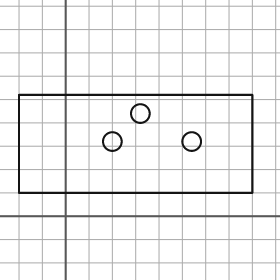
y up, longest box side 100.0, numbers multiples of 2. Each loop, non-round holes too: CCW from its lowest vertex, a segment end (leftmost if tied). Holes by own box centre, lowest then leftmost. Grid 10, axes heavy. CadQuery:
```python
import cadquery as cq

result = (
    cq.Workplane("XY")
    .moveTo(-20.0, 10.0)
    .lineTo(80.0, 10.0)
    .lineTo(80.0, 52.0)
    .lineTo(-20.0, 52.0)
    .close()
    .moveTo(20.0, 32.0)
    .circle(4.0)
    .moveTo(54.0, 32.0)
    .circle(4.0)
    .moveTo(32.0, 44.0)
    .circle(4.0)
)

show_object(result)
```